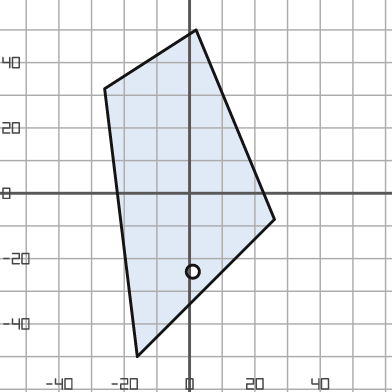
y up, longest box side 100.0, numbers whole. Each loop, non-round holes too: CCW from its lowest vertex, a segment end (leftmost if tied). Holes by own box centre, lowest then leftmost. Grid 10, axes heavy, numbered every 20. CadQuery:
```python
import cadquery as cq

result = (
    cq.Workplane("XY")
    .moveTo(-16.0, -50.0)
    .lineTo(26.0, -8.0)
    .lineTo(2.0, 50.0)
    .lineTo(-26.0, 32.0)
    .close()
    .moveTo(1.0, -24.0)
    .circle(2.0)
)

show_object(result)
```